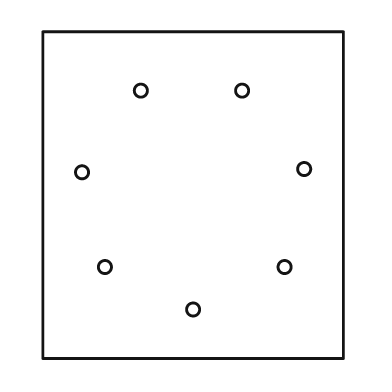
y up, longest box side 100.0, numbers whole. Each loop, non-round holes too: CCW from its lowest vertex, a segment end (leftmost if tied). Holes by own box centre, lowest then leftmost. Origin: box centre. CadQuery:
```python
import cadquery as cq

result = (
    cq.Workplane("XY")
    .moveTo(-46.0, -50.0)
    .lineTo(46.0, -50.0)
    .lineTo(46.0, 50.0)
    .lineTo(-46.0, 50.0)
    .close()
    .moveTo(0.0, -35.0)
    .circle(2.0)
    .moveTo(-27.0, -22.0)
    .circle(2.0)
    .moveTo(28.0, -22.0)
    .circle(2.0)
    .moveTo(-34.0, 7.0)
    .circle(2.0)
    .moveTo(34.0, 8.0)
    .circle(2.0)
    .moveTo(-16.0, 32.0)
    .circle(2.0)
    .moveTo(15.0, 32.0)
    .circle(2.0)
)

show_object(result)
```